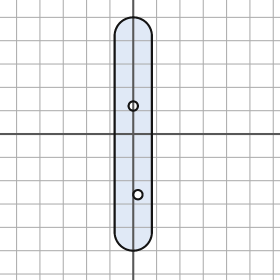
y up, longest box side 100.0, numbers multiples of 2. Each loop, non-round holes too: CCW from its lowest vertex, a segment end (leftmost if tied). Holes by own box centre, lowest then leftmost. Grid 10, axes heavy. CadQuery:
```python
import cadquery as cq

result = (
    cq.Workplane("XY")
    .moveTo(-8.0, -42.0)
    .threePointArc((0.0, -50.0), (8.0, -42.0))
    .lineTo(8.0, 42.0)
    .threePointArc((0.0, 50.0), (-8.0, 42.0))
    .close()
    .moveTo(2.0, -26.0)
    .circle(2.0)
    .moveTo(0.0, 12.0)
    .circle(2.0)
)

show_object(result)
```